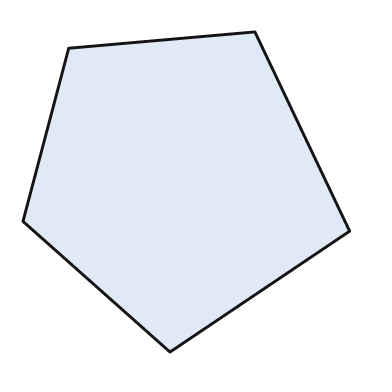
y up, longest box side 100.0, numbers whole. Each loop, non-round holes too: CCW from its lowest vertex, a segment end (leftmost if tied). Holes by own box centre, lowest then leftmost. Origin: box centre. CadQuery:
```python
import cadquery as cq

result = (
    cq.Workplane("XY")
    .moveTo(-5.0, -49.0)
    .lineTo(50.0, -12.0)
    .lineTo(21.0, 49.0)
    .lineTo(-36.0, 44.0)
    .lineTo(-50.0, -9.0)
    .close()
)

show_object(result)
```